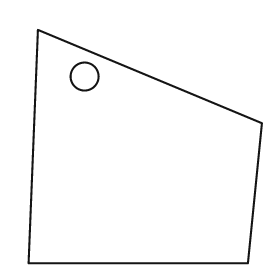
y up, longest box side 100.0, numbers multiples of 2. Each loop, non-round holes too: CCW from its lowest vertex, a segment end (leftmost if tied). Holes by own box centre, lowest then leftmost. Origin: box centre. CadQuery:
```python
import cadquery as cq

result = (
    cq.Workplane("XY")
    .moveTo(-50.0, -50.0)
    .lineTo(44.0, -50.0)
    .lineTo(50.0, 10.0)
    .lineTo(-46.0, 50.0)
    .close()
    .moveTo(-26.0, 30.0)
    .circle(6.0)
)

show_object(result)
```